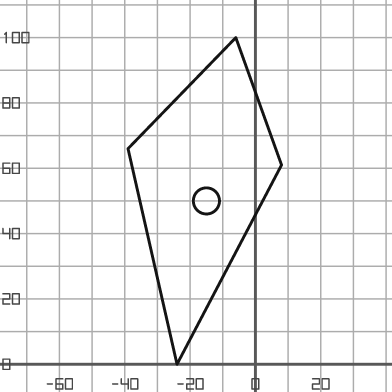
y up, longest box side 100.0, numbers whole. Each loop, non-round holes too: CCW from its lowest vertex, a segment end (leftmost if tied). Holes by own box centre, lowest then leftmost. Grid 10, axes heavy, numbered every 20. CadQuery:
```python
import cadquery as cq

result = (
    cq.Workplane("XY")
    .moveTo(-24.0, 0.0)
    .lineTo(8.0, 61.0)
    .lineTo(-6.0, 100.0)
    .lineTo(-39.0, 66.0)
    .close()
    .moveTo(-15.0, 50.0)
    .circle(4.0)
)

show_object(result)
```